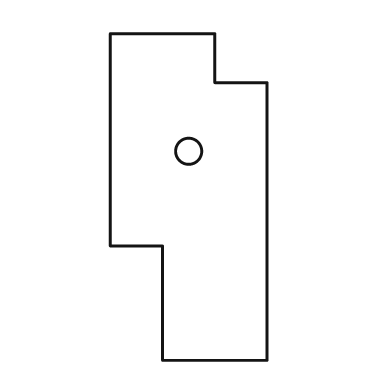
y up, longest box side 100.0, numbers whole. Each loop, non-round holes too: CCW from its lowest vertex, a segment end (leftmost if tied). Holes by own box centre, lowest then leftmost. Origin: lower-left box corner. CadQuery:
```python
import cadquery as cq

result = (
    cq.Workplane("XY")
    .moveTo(16.0, 0.0)
    .lineTo(48.0, 0.0)
    .lineTo(48.0, 85.0)
    .lineTo(32.0, 85.0)
    .lineTo(32.0, 100.0)
    .lineTo(0.0, 100.0)
    .lineTo(0.0, 35.0)
    .lineTo(16.0, 35.0)
    .close()
    .moveTo(24.0, 64.0)
    .circle(4.0)
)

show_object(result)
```